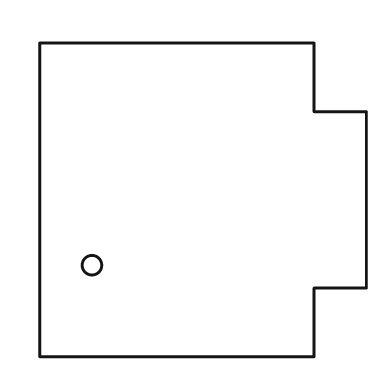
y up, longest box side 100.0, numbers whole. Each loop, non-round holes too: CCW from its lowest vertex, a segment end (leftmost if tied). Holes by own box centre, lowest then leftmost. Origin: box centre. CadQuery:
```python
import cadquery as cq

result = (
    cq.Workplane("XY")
    .moveTo(-50.0, -48.0)
    .lineTo(34.0, -48.0)
    .lineTo(34.0, -27.0)
    .lineTo(50.0, -27.0)
    .lineTo(50.0, 27.0)
    .lineTo(34.0, 27.0)
    .lineTo(34.0, 48.0)
    .lineTo(-50.0, 48.0)
    .close()
    .moveTo(-34.0, -20.0)
    .circle(3.0)
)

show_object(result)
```